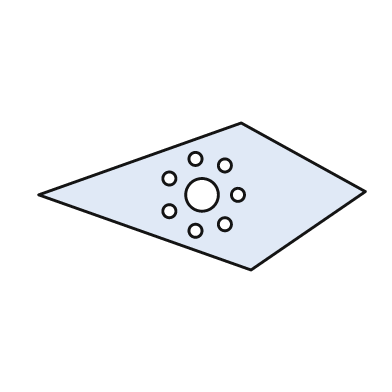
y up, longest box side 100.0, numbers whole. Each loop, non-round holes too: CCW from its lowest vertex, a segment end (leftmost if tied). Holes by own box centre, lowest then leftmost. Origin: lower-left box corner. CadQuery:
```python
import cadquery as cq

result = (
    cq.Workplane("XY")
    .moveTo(65.0, 0.0)
    .lineTo(100.0, 24.0)
    .lineTo(62.0, 45.0)
    .lineTo(0.0, 23.0)
    .close()
    .moveTo(48.0, 12.0)
    .circle(2.0)
    .moveTo(57.0, 14.0)
    .circle(2.0)
    .moveTo(40.0, 18.0)
    .circle(2.0)
    .moveTo(50.0, 23.0)
    .circle(5.0)
    .moveTo(61.0, 23.0)
    .circle(2.0)
    .moveTo(40.0, 28.0)
    .circle(2.0)
    .moveTo(57.0, 32.0)
    .circle(2.0)
    .moveTo(48.0, 34.0)
    .circle(2.0)
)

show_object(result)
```